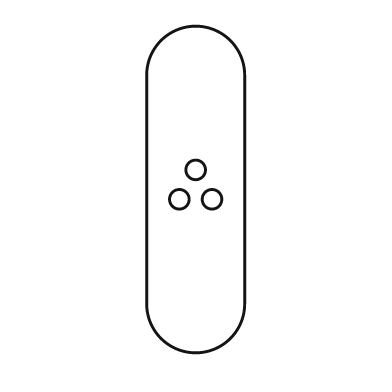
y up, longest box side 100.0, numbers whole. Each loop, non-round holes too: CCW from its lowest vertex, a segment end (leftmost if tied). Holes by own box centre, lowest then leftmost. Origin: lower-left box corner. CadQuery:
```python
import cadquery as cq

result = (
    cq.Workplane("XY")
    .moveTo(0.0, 15.0)
    .threePointArc((15.0, 0.0), (30.0, 15.0))
    .lineTo(30.0, 85.0)
    .threePointArc((15.0, 100.0), (0.0, 85.0))
    .close()
    .moveTo(10.0, 47.0)
    .circle(3.0)
    .moveTo(20.0, 47.0)
    .circle(3.0)
    .moveTo(15.0, 56.0)
    .circle(3.0)
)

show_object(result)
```